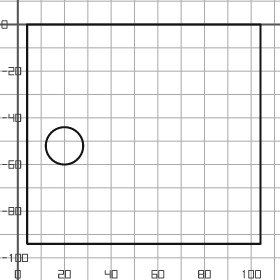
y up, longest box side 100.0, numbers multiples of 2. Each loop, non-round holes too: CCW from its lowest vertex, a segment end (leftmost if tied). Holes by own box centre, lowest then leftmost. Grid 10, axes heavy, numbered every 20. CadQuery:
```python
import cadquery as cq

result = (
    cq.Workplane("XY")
    .moveTo(4.0, -94.0)
    .lineTo(104.0, -94.0)
    .lineTo(104.0, 0.0)
    .lineTo(4.0, 0.0)
    .close()
    .moveTo(20.0, -52.0)
    .circle(8.0)
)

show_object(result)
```